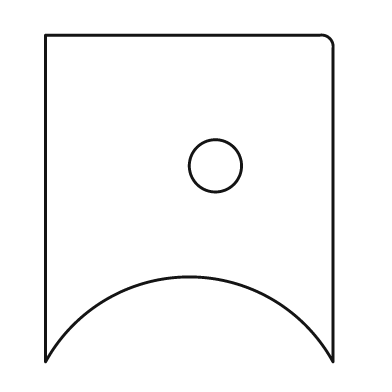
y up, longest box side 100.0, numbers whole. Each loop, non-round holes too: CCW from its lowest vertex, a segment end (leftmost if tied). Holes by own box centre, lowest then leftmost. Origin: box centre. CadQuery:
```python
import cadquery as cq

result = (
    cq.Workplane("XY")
    .moveTo(-44.0, -50.0)
    .threePointArc((0.0, -24.0), (44.0, -50.0))
    .lineTo(44.0, 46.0)
    .threePointArc((43.0, 49.0), (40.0, 50.0))
    .lineTo(-44.0, 50.0)
    .close()
    .moveTo(8.0, 10.0)
    .circle(8.0)
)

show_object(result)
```